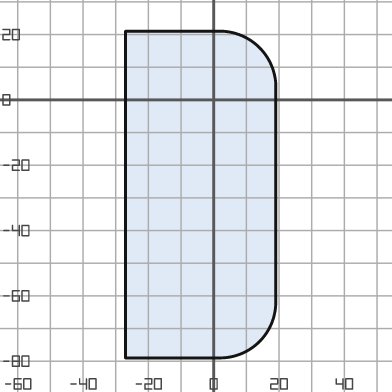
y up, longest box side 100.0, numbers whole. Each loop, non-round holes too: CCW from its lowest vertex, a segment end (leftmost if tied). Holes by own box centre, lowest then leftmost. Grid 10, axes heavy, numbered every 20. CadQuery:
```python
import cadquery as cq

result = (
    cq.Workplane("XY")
    .moveTo(-27.0, -79.0)
    .lineTo(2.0, -79.0)
    .threePointArc((14.0, -74.0), (19.0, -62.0))
    .lineTo(19.0, 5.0)
    .threePointArc((14.0, 16.0), (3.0, 21.0))
    .lineTo(-27.0, 21.0)
    .close()
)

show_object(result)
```